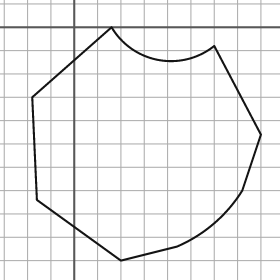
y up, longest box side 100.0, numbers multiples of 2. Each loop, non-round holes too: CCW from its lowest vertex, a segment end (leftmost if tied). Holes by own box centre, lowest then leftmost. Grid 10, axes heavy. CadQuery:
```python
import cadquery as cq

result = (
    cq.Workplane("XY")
    .moveTo(20.0, -100.0)
    .lineTo(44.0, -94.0)
    .threePointArc((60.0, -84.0), (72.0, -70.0))
    .lineTo(80.0, -46.0)
    .lineTo(60.0, -8.0)
    .threePointArc((36.0, -14.0), (16.0, 0.0))
    .lineTo(-18.0, -30.0)
    .lineTo(-16.0, -74.0)
    .close()
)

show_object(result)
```